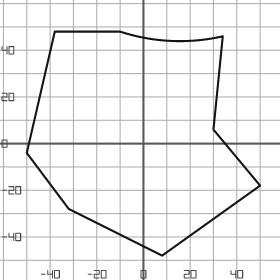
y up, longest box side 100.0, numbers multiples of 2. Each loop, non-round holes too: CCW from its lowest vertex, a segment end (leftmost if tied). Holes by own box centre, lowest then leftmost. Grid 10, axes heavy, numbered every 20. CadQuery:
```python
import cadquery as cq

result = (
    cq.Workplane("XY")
    .moveTo(8.0, -48.0)
    .lineTo(50.0, -18.0)
    .lineTo(30.0, 6.0)
    .lineTo(34.0, 46.0)
    .threePointArc((12.0, 44.0), (-10.0, 48.0))
    .lineTo(-38.0, 48.0)
    .lineTo(-50.0, -4.0)
    .lineTo(-32.0, -28.0)
    .close()
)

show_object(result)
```